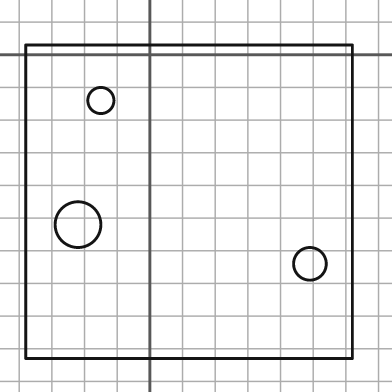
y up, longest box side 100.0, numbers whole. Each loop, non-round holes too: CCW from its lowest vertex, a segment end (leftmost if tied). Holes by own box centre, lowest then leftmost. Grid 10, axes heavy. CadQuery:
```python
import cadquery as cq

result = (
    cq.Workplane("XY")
    .moveTo(-38.0, -93.0)
    .lineTo(62.0, -93.0)
    .lineTo(62.0, 3.0)
    .lineTo(-38.0, 3.0)
    .close()
    .moveTo(49.0, -64.0)
    .circle(5.0)
    .moveTo(-22.0, -52.0)
    .circle(7.0)
    .moveTo(-15.0, -14.0)
    .circle(4.0)
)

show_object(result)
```